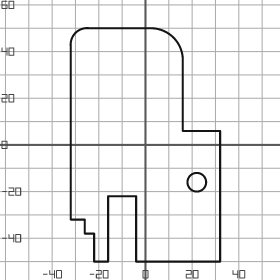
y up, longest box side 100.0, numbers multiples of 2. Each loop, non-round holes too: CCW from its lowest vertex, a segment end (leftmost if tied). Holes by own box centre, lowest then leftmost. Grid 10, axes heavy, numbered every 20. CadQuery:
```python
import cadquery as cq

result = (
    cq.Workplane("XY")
    .moveTo(-22.0, -50.0)
    .lineTo(-16.0, -50.0)
    .lineTo(-16.0, -22.0)
    .lineTo(-4.0, -22.0)
    .lineTo(-4.0, -50.0)
    .lineTo(32.0, -50.0)
    .lineTo(32.0, 6.0)
    .lineTo(16.0, 6.0)
    .lineTo(16.0, 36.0)
    .threePointArc((12.0, 46.0), (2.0, 50.0))
    .lineTo(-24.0, 50.0)
    .threePointArc((-30.0, 48.0), (-32.0, 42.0))
    .lineTo(-32.0, -32.0)
    .lineTo(-26.0, -32.0)
    .lineTo(-26.0, -38.0)
    .lineTo(-22.0, -38.0)
    .close()
    .moveTo(22.0, -16.0)
    .circle(4.0)
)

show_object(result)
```